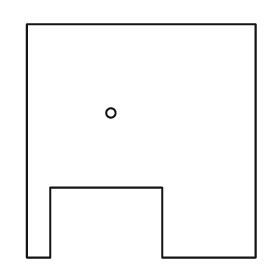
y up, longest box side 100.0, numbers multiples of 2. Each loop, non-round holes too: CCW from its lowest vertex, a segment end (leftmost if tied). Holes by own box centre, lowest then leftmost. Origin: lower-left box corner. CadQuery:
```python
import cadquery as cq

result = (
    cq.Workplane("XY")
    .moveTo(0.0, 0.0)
    .lineTo(10.0, 0.0)
    .lineTo(10.0, 30.0)
    .lineTo(58.0, 30.0)
    .lineTo(58.0, 0.0)
    .lineTo(98.0, 0.0)
    .lineTo(98.0, 100.0)
    .lineTo(0.0, 100.0)
    .close()
    .moveTo(36.0, 62.0)
    .circle(2.0)
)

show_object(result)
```